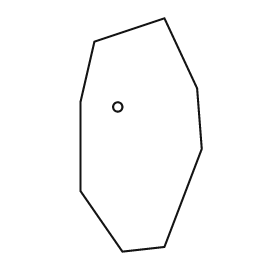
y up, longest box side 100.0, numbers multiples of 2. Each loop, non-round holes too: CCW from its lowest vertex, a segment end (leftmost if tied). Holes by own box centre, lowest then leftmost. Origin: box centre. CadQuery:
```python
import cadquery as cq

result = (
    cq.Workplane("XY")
    .moveTo(-8.0, -50.0)
    .lineTo(10.0, -48.0)
    .lineTo(26.0, -6.0)
    .lineTo(24.0, 20.0)
    .lineTo(10.0, 50.0)
    .lineTo(-20.0, 40.0)
    .lineTo(-26.0, 14.0)
    .lineTo(-26.0, -24.0)
    .close()
    .moveTo(-10.0, 12.0)
    .circle(2.0)
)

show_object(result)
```